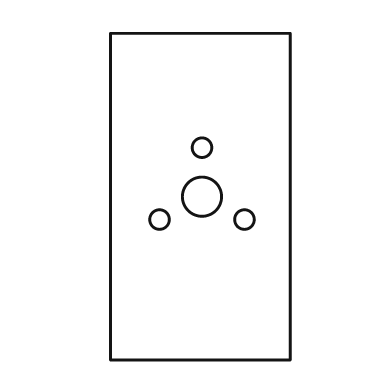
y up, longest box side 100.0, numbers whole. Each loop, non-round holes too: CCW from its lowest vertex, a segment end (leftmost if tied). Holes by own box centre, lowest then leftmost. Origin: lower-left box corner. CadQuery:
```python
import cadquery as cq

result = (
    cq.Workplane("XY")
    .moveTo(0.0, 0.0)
    .lineTo(55.0, 0.0)
    .lineTo(55.0, 100.0)
    .lineTo(0.0, 100.0)
    .close()
    .moveTo(15.0, 43.0)
    .circle(3.0)
    .moveTo(41.0, 43.0)
    .circle(3.0)
    .moveTo(28.0, 50.0)
    .circle(6.0)
    .moveTo(28.0, 65.0)
    .circle(3.0)
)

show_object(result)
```